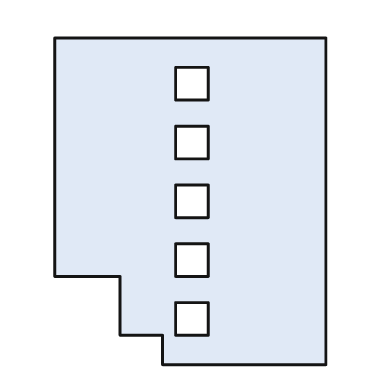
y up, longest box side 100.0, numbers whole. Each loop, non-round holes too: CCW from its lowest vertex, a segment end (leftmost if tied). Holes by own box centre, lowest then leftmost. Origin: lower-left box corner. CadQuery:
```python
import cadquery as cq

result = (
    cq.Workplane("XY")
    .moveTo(33.0, 0.0)
    .lineTo(83.0, 0.0)
    .lineTo(83.0, 100.0)
    .lineTo(0.0, 100.0)
    .lineTo(0.0, 27.0)
    .lineTo(20.0, 27.0)
    .lineTo(20.0, 9.0)
    .lineTo(33.0, 9.0)
    .close()
    .moveTo(37.0, 9.0)
    .lineTo(47.0, 9.0)
    .lineTo(47.0, 19.0)
    .lineTo(37.0, 19.0)
    .close()
    .moveTo(37.0, 27.0)
    .lineTo(47.0, 27.0)
    .lineTo(47.0, 37.0)
    .lineTo(37.0, 37.0)
    .close()
    .moveTo(37.0, 45.0)
    .lineTo(47.0, 45.0)
    .lineTo(47.0, 55.0)
    .lineTo(37.0, 55.0)
    .close()
    .moveTo(37.0, 63.0)
    .lineTo(47.0, 63.0)
    .lineTo(47.0, 73.0)
    .lineTo(37.0, 73.0)
    .close()
    .moveTo(37.0, 81.0)
    .lineTo(47.0, 81.0)
    .lineTo(47.0, 91.0)
    .lineTo(37.0, 91.0)
    .close()
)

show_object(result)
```